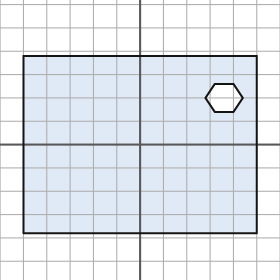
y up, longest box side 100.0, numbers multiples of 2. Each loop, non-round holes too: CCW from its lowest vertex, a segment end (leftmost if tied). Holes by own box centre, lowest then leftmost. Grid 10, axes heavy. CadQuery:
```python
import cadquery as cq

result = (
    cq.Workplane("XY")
    .moveTo(-50.0, -38.0)
    .lineTo(50.0, -38.0)
    .lineTo(50.0, 38.0)
    .lineTo(-50.0, 38.0)
    .close()
    .moveTo(32.0, 14.0)
    .lineTo(40.0, 14.0)
    .lineTo(44.0, 20.0)
    .lineTo(40.0, 26.0)
    .lineTo(32.0, 26.0)
    .lineTo(28.0, 20.0)
    .close()
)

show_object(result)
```